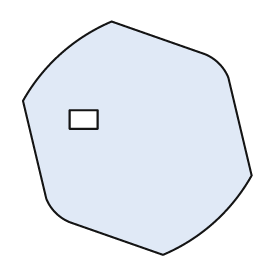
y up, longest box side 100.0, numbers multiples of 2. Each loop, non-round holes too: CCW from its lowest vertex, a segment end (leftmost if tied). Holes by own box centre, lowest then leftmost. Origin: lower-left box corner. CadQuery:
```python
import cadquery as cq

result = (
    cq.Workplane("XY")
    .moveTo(60.0, 0.0)
    .threePointArc((82.0, 14.0), (98.0, 34.0))
    .lineTo(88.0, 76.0)
    .threePointArc((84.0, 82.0), (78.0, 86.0))
    .lineTo(38.0, 100.0)
    .threePointArc((16.0, 86.0), (0.0, 66.0))
    .lineTo(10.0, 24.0)
    .threePointArc((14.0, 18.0), (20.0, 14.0))
    .close()
    .moveTo(20.0, 54.0)
    .lineTo(32.0, 54.0)
    .lineTo(32.0, 62.0)
    .lineTo(20.0, 62.0)
    .close()
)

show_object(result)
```